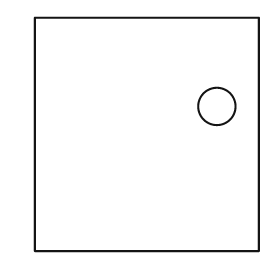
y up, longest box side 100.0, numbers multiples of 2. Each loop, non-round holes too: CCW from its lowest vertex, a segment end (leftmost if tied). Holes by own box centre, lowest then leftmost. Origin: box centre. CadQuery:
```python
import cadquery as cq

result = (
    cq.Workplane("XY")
    .moveTo(-48.0, -50.0)
    .lineTo(48.0, -50.0)
    .lineTo(48.0, 50.0)
    .lineTo(-48.0, 50.0)
    .close()
    .moveTo(30.0, 12.0)
    .circle(8.0)
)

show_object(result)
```